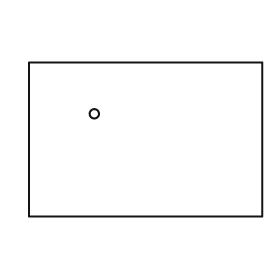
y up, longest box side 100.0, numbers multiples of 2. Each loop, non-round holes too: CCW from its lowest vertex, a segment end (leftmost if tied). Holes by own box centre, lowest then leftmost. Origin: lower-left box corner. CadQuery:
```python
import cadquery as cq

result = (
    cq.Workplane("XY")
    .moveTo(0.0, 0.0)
    .lineTo(100.0, 0.0)
    .lineTo(100.0, 66.0)
    .lineTo(0.0, 66.0)
    .close()
    .moveTo(28.0, 44.0)
    .circle(2.0)
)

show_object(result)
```